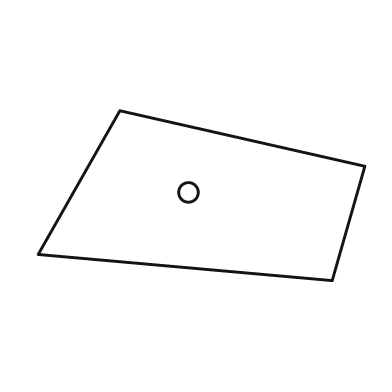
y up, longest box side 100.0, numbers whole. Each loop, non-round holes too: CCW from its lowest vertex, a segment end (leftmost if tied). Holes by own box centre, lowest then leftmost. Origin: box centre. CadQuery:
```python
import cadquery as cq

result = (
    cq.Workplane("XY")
    .moveTo(40.0, -26.0)
    .lineTo(50.0, 9.0)
    .lineTo(-25.0, 26.0)
    .lineTo(-50.0, -18.0)
    .close()
    .moveTo(-4.0, 1.0)
    .circle(3.0)
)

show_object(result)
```